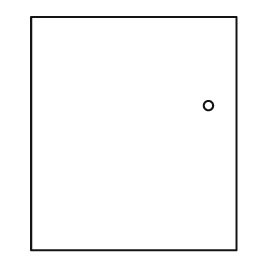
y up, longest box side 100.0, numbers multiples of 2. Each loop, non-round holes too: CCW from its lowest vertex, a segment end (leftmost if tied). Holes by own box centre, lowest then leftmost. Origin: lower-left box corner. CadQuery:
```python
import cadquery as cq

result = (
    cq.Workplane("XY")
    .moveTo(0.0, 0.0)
    .lineTo(88.0, 0.0)
    .lineTo(88.0, 100.0)
    .lineTo(0.0, 100.0)
    .close()
    .moveTo(76.0, 62.0)
    .circle(2.0)
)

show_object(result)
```